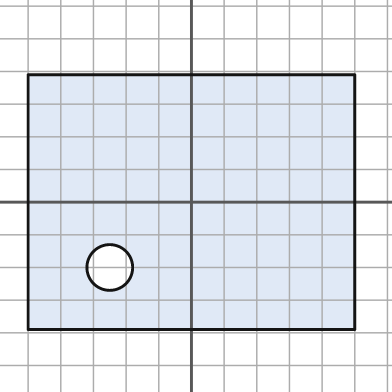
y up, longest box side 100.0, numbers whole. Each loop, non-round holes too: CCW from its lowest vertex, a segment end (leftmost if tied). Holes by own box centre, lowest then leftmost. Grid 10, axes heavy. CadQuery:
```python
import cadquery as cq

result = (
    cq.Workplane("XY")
    .moveTo(-50.0, -39.0)
    .lineTo(50.0, -39.0)
    .lineTo(50.0, 39.0)
    .lineTo(-50.0, 39.0)
    .close()
    .moveTo(-25.0, -20.0)
    .circle(7.0)
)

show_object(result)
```